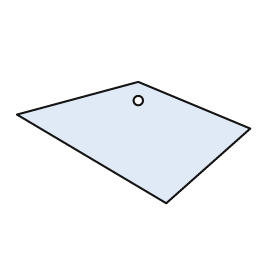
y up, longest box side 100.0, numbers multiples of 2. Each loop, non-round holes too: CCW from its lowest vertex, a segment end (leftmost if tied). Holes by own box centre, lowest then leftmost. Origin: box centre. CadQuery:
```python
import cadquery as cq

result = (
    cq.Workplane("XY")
    .moveTo(14.0, -26.0)
    .lineTo(50.0, 6.0)
    .lineTo(2.0, 26.0)
    .lineTo(-50.0, 12.0)
    .close()
    .moveTo(2.0, 18.0)
    .circle(2.0)
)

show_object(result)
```